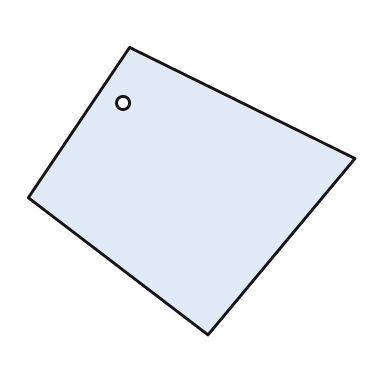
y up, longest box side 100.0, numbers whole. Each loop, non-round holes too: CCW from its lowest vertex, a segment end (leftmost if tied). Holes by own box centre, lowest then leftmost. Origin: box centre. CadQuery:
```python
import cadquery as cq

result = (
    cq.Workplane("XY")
    .moveTo(5.0, -44.0)
    .lineTo(50.0, 10.0)
    .lineTo(-19.0, 44.0)
    .lineTo(-50.0, -2.0)
    .close()
    .moveTo(-21.0, 27.0)
    .circle(2.0)
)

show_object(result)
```